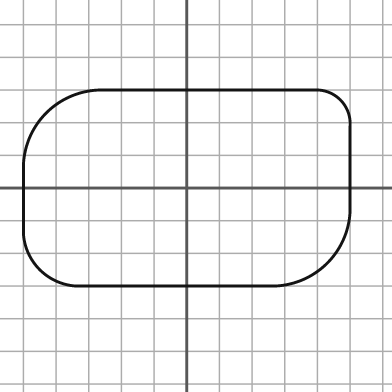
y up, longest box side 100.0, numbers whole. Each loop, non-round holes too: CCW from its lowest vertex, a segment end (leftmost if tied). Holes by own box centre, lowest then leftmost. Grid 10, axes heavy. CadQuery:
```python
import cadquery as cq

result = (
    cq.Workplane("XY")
    .moveTo(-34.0, -30.0)
    .lineTo(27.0, -30.0)
    .threePointArc((43.0, -23.0), (50.0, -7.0))
    .lineTo(50.0, 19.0)
    .threePointArc((47.0, 27.0), (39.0, 30.0))
    .lineTo(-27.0, 30.0)
    .threePointArc((-43.0, 23.0), (-50.0, 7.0))
    .lineTo(-50.0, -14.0)
    .threePointArc((-45.0, -25.0), (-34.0, -30.0))
    .close()
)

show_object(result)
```